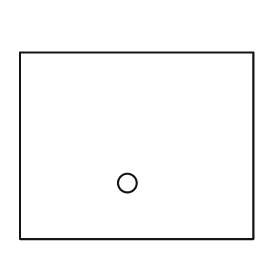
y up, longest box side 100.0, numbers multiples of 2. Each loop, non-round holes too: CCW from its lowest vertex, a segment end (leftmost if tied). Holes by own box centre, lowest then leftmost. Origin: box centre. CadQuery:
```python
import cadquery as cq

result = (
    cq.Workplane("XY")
    .moveTo(-50.0, -40.0)
    .lineTo(50.0, -40.0)
    .lineTo(50.0, 40.0)
    .lineTo(-50.0, 40.0)
    .close()
    .moveTo(-4.0, -16.0)
    .circle(4.0)
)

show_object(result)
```